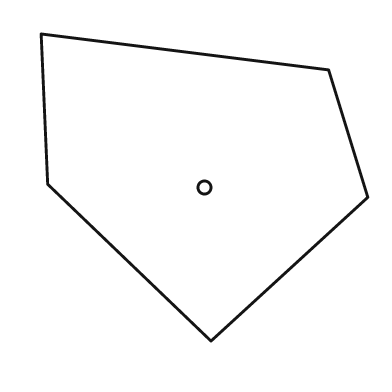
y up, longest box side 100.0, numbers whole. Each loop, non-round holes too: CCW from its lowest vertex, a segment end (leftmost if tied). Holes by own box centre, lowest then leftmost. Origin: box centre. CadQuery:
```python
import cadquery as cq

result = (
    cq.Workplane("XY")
    .moveTo(2.0, -47.0)
    .lineTo(50.0, -3.0)
    .lineTo(38.0, 36.0)
    .lineTo(-50.0, 47.0)
    .lineTo(-48.0, 1.0)
    .close()
    .moveTo(0.0, 0.0)
    .circle(2.0)
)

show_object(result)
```